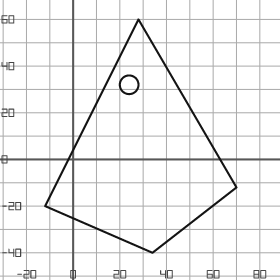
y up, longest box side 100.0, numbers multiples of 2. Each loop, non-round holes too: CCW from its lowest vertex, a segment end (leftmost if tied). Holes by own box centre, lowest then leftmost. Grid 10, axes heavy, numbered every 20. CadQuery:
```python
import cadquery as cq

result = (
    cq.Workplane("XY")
    .moveTo(34.0, -40.0)
    .lineTo(70.0, -12.0)
    .lineTo(28.0, 60.0)
    .lineTo(-12.0, -20.0)
    .close()
    .moveTo(24.0, 32.0)
    .circle(4.0)
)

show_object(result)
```